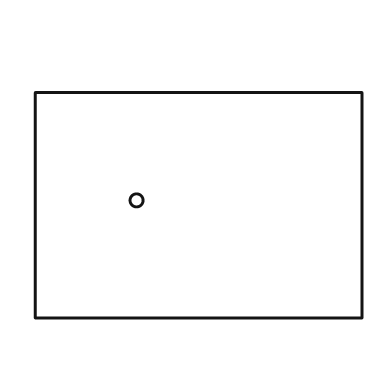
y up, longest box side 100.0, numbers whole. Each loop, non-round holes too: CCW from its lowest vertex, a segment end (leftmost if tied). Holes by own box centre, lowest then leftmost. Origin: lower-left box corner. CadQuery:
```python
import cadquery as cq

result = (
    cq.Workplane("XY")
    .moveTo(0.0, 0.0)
    .lineTo(100.0, 0.0)
    .lineTo(100.0, 69.0)
    .lineTo(0.0, 69.0)
    .close()
    .moveTo(31.0, 36.0)
    .circle(2.0)
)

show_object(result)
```